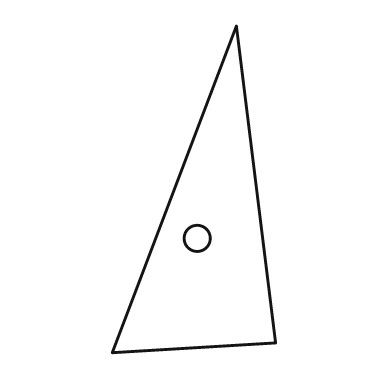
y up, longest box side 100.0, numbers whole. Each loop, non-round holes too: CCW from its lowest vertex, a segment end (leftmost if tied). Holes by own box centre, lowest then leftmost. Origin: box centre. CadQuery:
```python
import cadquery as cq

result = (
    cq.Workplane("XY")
    .moveTo(-25.0, -50.0)
    .lineTo(25.0, -47.0)
    .lineTo(13.0, 50.0)
    .close()
    .moveTo(1.0, -15.0)
    .circle(4.0)
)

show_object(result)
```